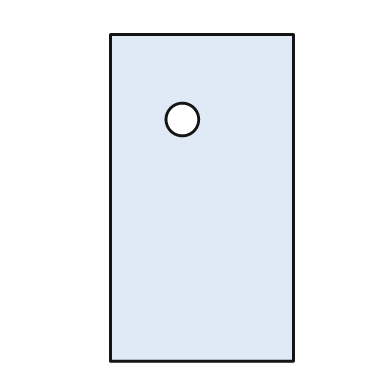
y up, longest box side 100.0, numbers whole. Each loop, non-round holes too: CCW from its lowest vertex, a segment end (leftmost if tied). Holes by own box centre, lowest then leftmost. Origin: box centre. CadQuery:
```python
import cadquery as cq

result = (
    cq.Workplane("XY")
    .moveTo(-28.0, -50.0)
    .lineTo(28.0, -50.0)
    .lineTo(28.0, 50.0)
    .lineTo(-28.0, 50.0)
    .close()
    .moveTo(-6.0, 24.0)
    .circle(5.0)
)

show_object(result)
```